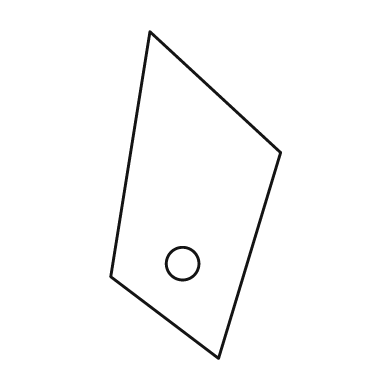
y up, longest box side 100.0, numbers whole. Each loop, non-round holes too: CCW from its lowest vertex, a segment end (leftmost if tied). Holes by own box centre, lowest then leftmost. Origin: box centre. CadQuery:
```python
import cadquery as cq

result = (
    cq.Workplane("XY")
    .moveTo(7.0, -50.0)
    .lineTo(26.0, 13.0)
    .lineTo(-14.0, 50.0)
    .lineTo(-26.0, -25.0)
    .close()
    .moveTo(-4.0, -21.0)
    .circle(5.0)
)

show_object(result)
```